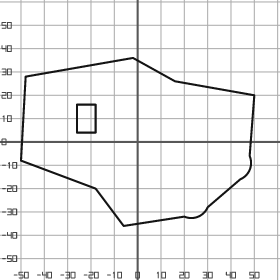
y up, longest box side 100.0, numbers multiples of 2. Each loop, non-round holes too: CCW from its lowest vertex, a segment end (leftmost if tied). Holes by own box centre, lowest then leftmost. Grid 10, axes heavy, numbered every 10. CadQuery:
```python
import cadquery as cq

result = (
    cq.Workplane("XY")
    .moveTo(-6.0, -36.0)
    .lineTo(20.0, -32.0)
    .threePointArc((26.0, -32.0), (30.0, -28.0))
    .lineTo(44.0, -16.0)
    .threePointArc((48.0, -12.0), (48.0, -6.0))
    .lineTo(50.0, 20.0)
    .lineTo(16.0, 26.0)
    .lineTo(-2.0, 36.0)
    .lineTo(-48.0, 28.0)
    .lineTo(-50.0, -8.0)
    .lineTo(-18.0, -20.0)
    .close()
    .moveTo(-26.0, 4.0)
    .lineTo(-18.0, 4.0)
    .lineTo(-18.0, 16.0)
    .lineTo(-26.0, 16.0)
    .close()
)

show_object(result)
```